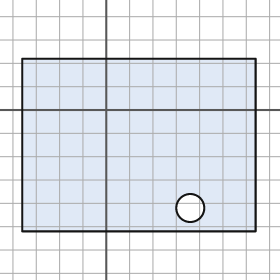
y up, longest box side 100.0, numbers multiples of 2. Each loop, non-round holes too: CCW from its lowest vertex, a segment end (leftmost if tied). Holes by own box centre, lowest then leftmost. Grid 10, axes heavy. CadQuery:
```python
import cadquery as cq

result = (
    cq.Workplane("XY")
    .moveTo(-36.0, -52.0)
    .lineTo(64.0, -52.0)
    .lineTo(64.0, 22.0)
    .lineTo(-36.0, 22.0)
    .close()
    .moveTo(36.0, -42.0)
    .circle(6.0)
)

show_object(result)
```